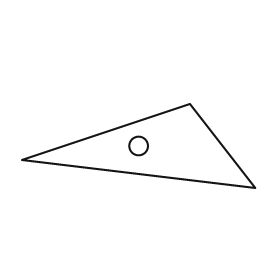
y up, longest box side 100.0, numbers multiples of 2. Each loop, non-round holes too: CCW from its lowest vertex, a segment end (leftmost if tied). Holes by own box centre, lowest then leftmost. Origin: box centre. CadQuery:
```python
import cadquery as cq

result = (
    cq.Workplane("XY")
    .moveTo(50.0, -18.0)
    .lineTo(22.0, 18.0)
    .lineTo(-50.0, -6.0)
    .close()
    .moveTo(0.0, 0.0)
    .circle(4.0)
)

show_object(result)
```